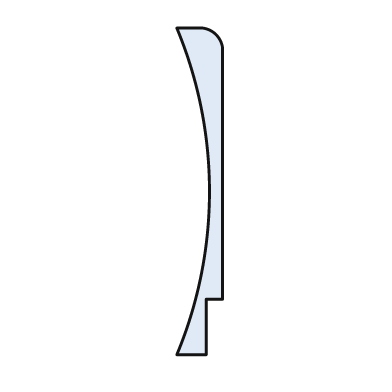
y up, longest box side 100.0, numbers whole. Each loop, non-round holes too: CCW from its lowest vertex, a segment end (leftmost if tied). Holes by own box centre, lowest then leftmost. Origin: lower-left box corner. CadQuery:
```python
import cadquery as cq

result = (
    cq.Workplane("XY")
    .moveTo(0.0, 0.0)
    .lineTo(9.0, 0.0)
    .lineTo(9.0, 17.0)
    .lineTo(14.0, 17.0)
    .lineTo(14.0, 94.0)
    .threePointArc((12.0, 98.0), (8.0, 100.0))
    .lineTo(0.0, 100.0)
    .threePointArc((10.0, 50.0), (0.0, 0.0))
    .close()
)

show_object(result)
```